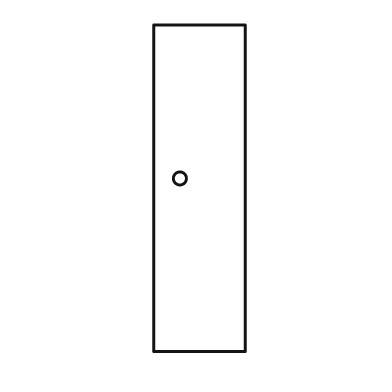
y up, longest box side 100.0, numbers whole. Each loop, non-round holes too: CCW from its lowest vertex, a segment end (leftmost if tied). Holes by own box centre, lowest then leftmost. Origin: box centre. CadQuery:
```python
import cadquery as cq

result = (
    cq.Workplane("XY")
    .moveTo(-14.0, -50.0)
    .lineTo(14.0, -50.0)
    .lineTo(14.0, 50.0)
    .lineTo(-14.0, 50.0)
    .close()
    .moveTo(-6.0, 3.0)
    .circle(2.0)
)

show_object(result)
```